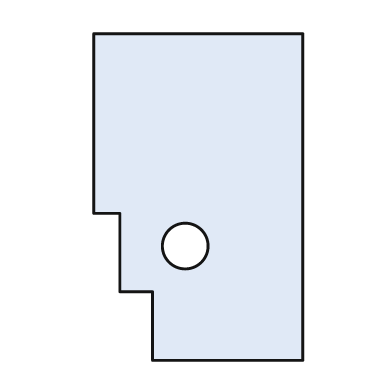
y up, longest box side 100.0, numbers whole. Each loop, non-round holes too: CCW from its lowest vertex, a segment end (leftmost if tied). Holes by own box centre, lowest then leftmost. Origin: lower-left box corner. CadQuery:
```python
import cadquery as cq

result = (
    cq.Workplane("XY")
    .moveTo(18.0, 0.0)
    .lineTo(64.0, 0.0)
    .lineTo(64.0, 100.0)
    .lineTo(0.0, 100.0)
    .lineTo(0.0, 45.0)
    .lineTo(8.0, 45.0)
    .lineTo(8.0, 21.0)
    .lineTo(18.0, 21.0)
    .close()
    .moveTo(28.0, 35.0)
    .circle(7.0)
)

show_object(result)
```